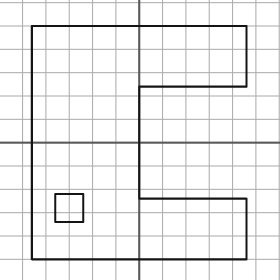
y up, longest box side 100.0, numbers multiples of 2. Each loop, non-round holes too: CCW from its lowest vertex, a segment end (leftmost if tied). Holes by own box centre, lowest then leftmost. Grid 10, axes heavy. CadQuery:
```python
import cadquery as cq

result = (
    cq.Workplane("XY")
    .moveTo(-46.0, -50.0)
    .lineTo(46.0, -50.0)
    .lineTo(46.0, -24.0)
    .lineTo(0.0, -24.0)
    .lineTo(0.0, 24.0)
    .lineTo(46.0, 24.0)
    .lineTo(46.0, 50.0)
    .lineTo(-46.0, 50.0)
    .close()
    .moveTo(-36.0, -34.0)
    .lineTo(-24.0, -34.0)
    .lineTo(-24.0, -22.0)
    .lineTo(-36.0, -22.0)
    .close()
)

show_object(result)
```